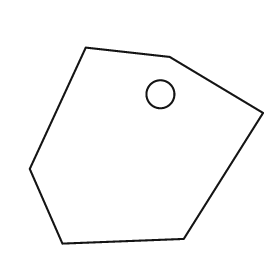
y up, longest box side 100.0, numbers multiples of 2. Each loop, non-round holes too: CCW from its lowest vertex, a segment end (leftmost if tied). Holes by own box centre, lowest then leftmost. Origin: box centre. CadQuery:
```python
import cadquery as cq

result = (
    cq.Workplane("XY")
    .moveTo(-36.0, -42.0)
    .lineTo(16.0, -40.0)
    .lineTo(50.0, 14.0)
    .lineTo(10.0, 38.0)
    .lineTo(-26.0, 42.0)
    .lineTo(-50.0, -10.0)
    .close()
    .moveTo(6.0, 22.0)
    .circle(6.0)
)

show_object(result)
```